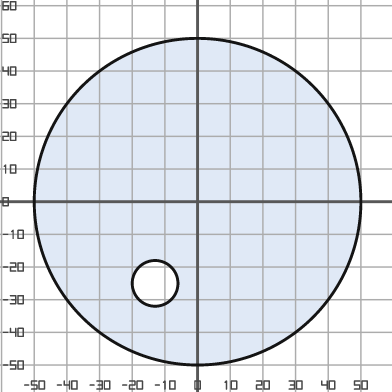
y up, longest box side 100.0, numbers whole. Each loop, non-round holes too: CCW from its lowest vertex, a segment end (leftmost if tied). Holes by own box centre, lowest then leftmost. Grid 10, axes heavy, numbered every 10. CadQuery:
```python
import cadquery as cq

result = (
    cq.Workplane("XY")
    .moveTo(0.0, 0.0)
    .circle(50.0)
    .moveTo(-13.0, -25.0)
    .circle(7.0)
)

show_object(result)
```